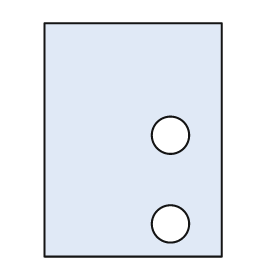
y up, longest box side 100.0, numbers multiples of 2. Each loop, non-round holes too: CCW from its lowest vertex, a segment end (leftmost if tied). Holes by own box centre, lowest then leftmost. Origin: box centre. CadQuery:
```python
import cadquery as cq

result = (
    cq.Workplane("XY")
    .moveTo(-38.0, -50.0)
    .lineTo(38.0, -50.0)
    .lineTo(38.0, 50.0)
    .lineTo(-38.0, 50.0)
    .close()
    .moveTo(16.0, -36.0)
    .circle(8.0)
    .moveTo(16.0, 2.0)
    .circle(8.0)
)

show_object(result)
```